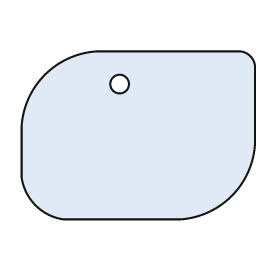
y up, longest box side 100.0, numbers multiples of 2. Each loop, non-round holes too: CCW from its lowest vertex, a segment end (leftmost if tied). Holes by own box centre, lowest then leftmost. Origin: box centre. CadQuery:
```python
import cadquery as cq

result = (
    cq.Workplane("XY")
    .moveTo(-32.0, -36.0)
    .lineTo(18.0, -36.0)
    .threePointArc((40.0, -26.0), (50.0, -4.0))
    .lineTo(50.0, 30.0)
    .threePointArc((48.0, 34.0), (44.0, 36.0))
    .lineTo(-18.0, 36.0)
    .threePointArc((-40.0, 26.0), (-50.0, 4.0))
    .lineTo(-50.0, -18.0)
    .threePointArc((-44.0, -30.0), (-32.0, -36.0))
    .close()
    .moveTo(-8.0, 22.0)
    .circle(4.0)
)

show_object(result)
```